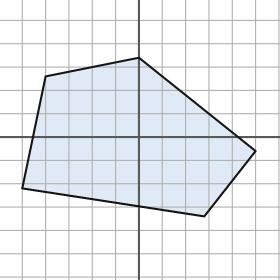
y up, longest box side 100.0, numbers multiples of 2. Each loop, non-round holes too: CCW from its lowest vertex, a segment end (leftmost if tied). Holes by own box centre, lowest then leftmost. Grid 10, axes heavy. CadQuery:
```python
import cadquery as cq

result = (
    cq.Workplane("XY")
    .moveTo(28.0, -34.0)
    .lineTo(50.0, -6.0)
    .lineTo(0.0, 34.0)
    .lineTo(-40.0, 26.0)
    .lineTo(-50.0, -22.0)
    .close()
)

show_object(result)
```